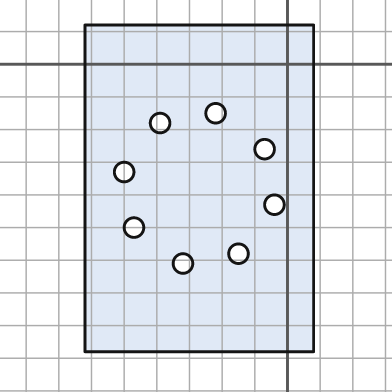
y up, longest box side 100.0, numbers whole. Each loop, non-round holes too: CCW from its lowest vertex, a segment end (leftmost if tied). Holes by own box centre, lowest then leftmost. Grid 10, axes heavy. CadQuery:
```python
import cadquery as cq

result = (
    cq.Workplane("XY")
    .moveTo(-62.0, -88.0)
    .lineTo(8.0, -88.0)
    .lineTo(8.0, 12.0)
    .lineTo(-62.0, 12.0)
    .close()
    .moveTo(-32.0, -61.0)
    .circle(3.0)
    .moveTo(-15.0, -58.0)
    .circle(3.0)
    .moveTo(-47.0, -50.0)
    .circle(3.0)
    .moveTo(-4.0, -43.0)
    .circle(3.0)
    .moveTo(-50.0, -33.0)
    .circle(3.0)
    .moveTo(-7.0, -26.0)
    .circle(3.0)
    .moveTo(-39.0, -18.0)
    .circle(3.0)
    .moveTo(-22.0, -15.0)
    .circle(3.0)
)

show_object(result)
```